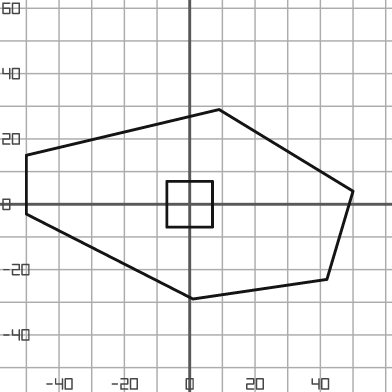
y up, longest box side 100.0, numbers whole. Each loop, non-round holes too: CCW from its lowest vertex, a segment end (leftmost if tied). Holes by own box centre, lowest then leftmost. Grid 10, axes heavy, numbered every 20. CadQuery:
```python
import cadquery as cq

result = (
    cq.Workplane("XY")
    .moveTo(1.0, -29.0)
    .lineTo(42.0, -23.0)
    .lineTo(50.0, 4.0)
    .lineTo(9.0, 29.0)
    .lineTo(-50.0, 15.0)
    .lineTo(-50.0, -3.0)
    .close()
    .moveTo(-7.0, -7.0)
    .lineTo(7.0, -7.0)
    .lineTo(7.0, 7.0)
    .lineTo(-7.0, 7.0)
    .close()
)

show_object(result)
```